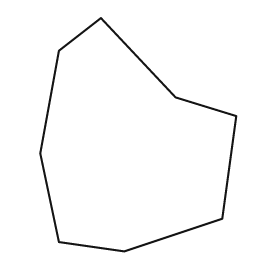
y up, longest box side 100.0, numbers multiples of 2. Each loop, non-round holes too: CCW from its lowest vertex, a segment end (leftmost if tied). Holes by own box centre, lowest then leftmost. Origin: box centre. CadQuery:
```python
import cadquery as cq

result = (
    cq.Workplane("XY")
    .moveTo(-6.0, -50.0)
    .lineTo(36.0, -36.0)
    .lineTo(42.0, 8.0)
    .lineTo(16.0, 16.0)
    .lineTo(-16.0, 50.0)
    .lineTo(-34.0, 36.0)
    .lineTo(-42.0, -8.0)
    .lineTo(-34.0, -46.0)
    .close()
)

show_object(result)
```